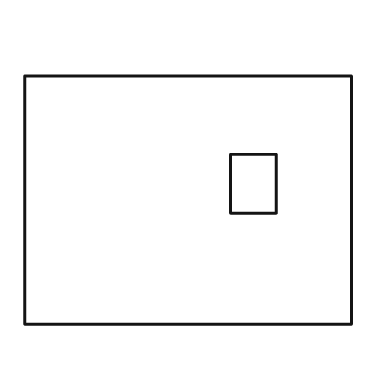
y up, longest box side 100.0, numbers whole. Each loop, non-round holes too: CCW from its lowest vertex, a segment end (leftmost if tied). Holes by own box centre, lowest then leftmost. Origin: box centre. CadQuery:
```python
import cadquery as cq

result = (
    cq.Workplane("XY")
    .moveTo(-50.0, -38.0)
    .lineTo(50.0, -38.0)
    .lineTo(50.0, 38.0)
    .lineTo(-50.0, 38.0)
    .close()
    .moveTo(13.0, -4.0)
    .lineTo(27.0, -4.0)
    .lineTo(27.0, 14.0)
    .lineTo(13.0, 14.0)
    .close()
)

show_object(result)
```